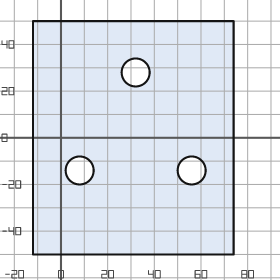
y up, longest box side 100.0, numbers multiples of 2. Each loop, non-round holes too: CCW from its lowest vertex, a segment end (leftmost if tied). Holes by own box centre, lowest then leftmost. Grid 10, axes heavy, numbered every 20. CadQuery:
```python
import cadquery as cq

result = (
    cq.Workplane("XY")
    .moveTo(-12.0, -50.0)
    .lineTo(74.0, -50.0)
    .lineTo(74.0, 50.0)
    .lineTo(-12.0, 50.0)
    .close()
    .moveTo(8.0, -14.0)
    .circle(6.0)
    .moveTo(56.0, -14.0)
    .circle(6.0)
    .moveTo(32.0, 28.0)
    .circle(6.0)
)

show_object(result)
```